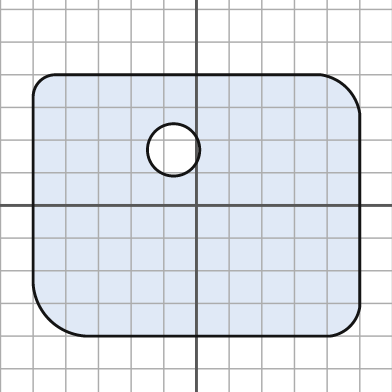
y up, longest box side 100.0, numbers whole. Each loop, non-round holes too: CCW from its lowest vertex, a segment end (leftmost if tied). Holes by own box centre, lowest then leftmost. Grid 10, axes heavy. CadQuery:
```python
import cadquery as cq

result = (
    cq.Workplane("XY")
    .moveTo(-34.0, -40.0)
    .lineTo(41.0, -40.0)
    .threePointArc((47.0, -37.0), (50.0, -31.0))
    .lineTo(50.0, 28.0)
    .threePointArc((46.0, 36.0), (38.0, 40.0))
    .lineTo(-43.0, 40.0)
    .threePointArc((-48.0, 38.0), (-50.0, 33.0))
    .lineTo(-50.0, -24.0)
    .threePointArc((-45.0, -35.0), (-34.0, -40.0))
    .close()
    .moveTo(-7.0, 17.0)
    .circle(8.0)
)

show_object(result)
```